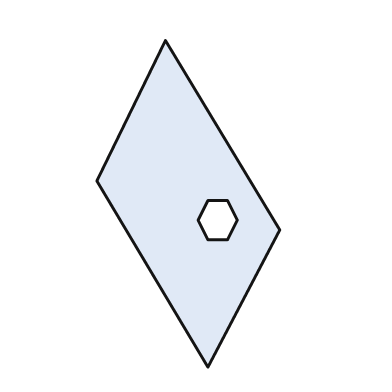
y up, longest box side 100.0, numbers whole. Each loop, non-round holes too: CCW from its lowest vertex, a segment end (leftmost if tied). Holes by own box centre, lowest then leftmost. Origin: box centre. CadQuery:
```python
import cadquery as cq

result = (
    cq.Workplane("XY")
    .moveTo(6.0, -50.0)
    .lineTo(28.0, -8.0)
    .lineTo(-7.0, 50.0)
    .lineTo(-28.0, 7.0)
    .close()
    .moveTo(6.0, -11.0)
    .lineTo(12.0, -11.0)
    .lineTo(15.0, -5.0)
    .lineTo(12.0, 1.0)
    .lineTo(6.0, 1.0)
    .lineTo(3.0, -5.0)
    .close()
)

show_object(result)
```